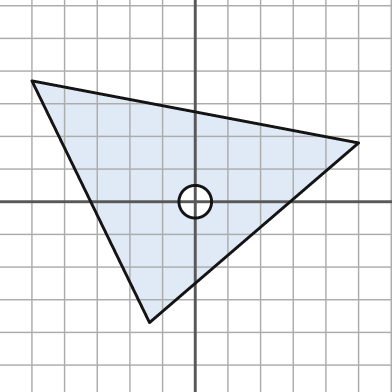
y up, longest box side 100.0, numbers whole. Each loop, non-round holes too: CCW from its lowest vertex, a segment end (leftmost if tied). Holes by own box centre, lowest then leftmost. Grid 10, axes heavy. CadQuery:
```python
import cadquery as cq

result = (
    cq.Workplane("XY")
    .moveTo(-14.0, -37.0)
    .lineTo(50.0, 18.0)
    .lineTo(-50.0, 37.0)
    .close()
    .moveTo(0.0, 0.0)
    .circle(5.0)
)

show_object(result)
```